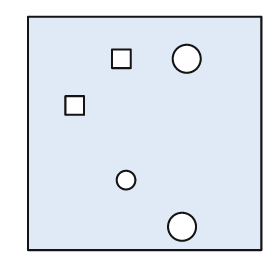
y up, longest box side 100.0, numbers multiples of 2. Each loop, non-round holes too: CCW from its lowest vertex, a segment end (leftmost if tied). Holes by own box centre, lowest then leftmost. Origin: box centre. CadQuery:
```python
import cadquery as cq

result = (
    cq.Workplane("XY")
    .moveTo(-50.0, -50.0)
    .lineTo(50.0, -50.0)
    .lineTo(50.0, 50.0)
    .lineTo(-50.0, 50.0)
    .close()
    .moveTo(16.0, -40.0)
    .circle(6.0)
    .moveTo(-8.0, -20.0)
    .circle(4.0)
    .moveTo(-34.0, 8.0)
    .lineTo(-26.0, 8.0)
    .lineTo(-26.0, 16.0)
    .lineTo(-34.0, 16.0)
    .close()
    .moveTo(-14.0, 28.0)
    .lineTo(-6.0, 28.0)
    .lineTo(-6.0, 36.0)
    .lineTo(-14.0, 36.0)
    .close()
    .moveTo(18.0, 32.0)
    .circle(6.0)
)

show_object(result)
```